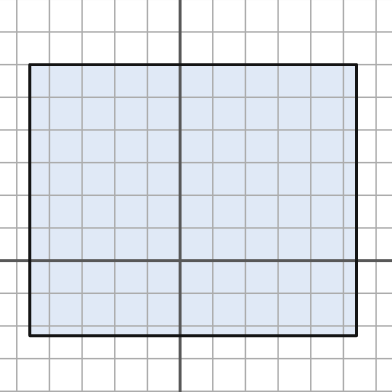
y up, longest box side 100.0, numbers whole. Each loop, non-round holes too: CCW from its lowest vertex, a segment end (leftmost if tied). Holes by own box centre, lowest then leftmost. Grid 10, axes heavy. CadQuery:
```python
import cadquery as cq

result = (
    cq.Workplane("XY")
    .moveTo(-46.0, -23.0)
    .lineTo(54.0, -23.0)
    .lineTo(54.0, 60.0)
    .lineTo(-46.0, 60.0)
    .close()
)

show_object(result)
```